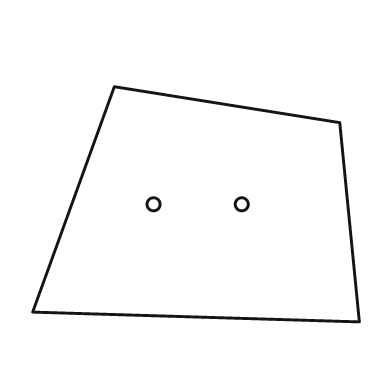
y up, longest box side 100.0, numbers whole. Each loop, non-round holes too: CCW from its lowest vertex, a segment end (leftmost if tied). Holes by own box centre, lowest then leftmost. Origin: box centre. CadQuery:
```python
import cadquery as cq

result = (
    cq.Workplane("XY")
    .moveTo(50.0, -36.0)
    .lineTo(44.0, 25.0)
    .lineTo(-25.0, 36.0)
    .lineTo(-50.0, -33.0)
    .close()
    .moveTo(-13.0, 0.0)
    .circle(2.0)
    .moveTo(14.0, 0.0)
    .circle(2.0)
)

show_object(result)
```